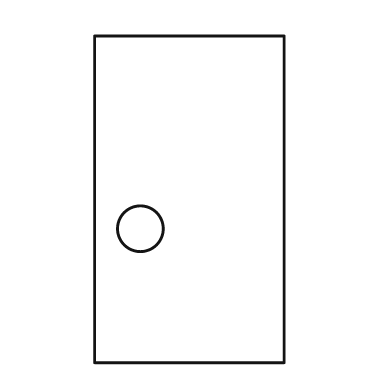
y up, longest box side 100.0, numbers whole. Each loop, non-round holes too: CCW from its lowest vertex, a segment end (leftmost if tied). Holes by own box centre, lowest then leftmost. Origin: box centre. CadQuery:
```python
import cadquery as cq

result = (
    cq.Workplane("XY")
    .moveTo(-29.0, -50.0)
    .lineTo(29.0, -50.0)
    .lineTo(29.0, 50.0)
    .lineTo(-29.0, 50.0)
    .close()
    .moveTo(-15.0, -9.0)
    .circle(7.0)
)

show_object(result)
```